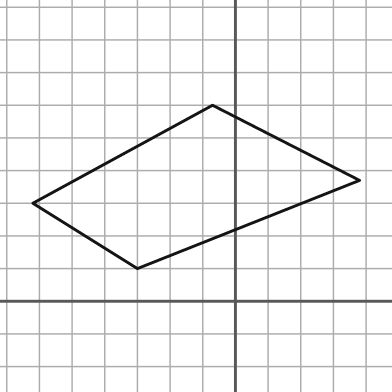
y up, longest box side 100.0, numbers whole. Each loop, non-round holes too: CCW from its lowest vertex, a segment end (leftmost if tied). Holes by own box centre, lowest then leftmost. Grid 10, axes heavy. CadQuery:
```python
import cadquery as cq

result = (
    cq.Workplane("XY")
    .moveTo(-30.0, 10.0)
    .lineTo(38.0, 37.0)
    .lineTo(-7.0, 60.0)
    .lineTo(-62.0, 30.0)
    .close()
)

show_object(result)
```